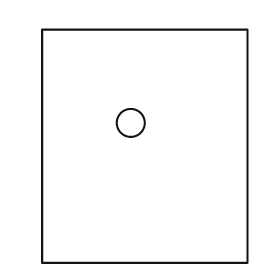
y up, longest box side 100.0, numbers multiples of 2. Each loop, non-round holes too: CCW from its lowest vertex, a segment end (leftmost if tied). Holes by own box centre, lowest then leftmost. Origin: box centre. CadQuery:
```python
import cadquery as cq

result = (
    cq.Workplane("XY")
    .moveTo(-44.0, -50.0)
    .lineTo(44.0, -50.0)
    .lineTo(44.0, 50.0)
    .lineTo(-44.0, 50.0)
    .close()
    .moveTo(-6.0, 10.0)
    .circle(6.0)
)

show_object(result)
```